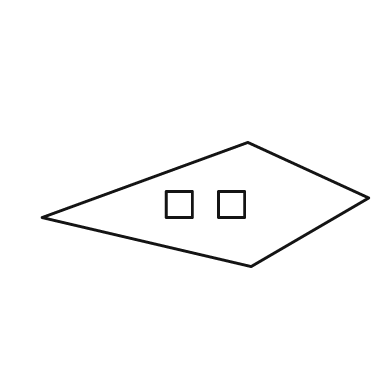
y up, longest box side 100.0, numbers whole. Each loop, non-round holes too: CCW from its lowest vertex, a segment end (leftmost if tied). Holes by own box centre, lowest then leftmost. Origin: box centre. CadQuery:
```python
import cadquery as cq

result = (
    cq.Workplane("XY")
    .moveTo(14.0, -19.0)
    .lineTo(50.0, 2.0)
    .lineTo(13.0, 19.0)
    .lineTo(-50.0, -4.0)
    .close()
    .moveTo(-12.0, -4.0)
    .lineTo(-4.0, -4.0)
    .lineTo(-4.0, 4.0)
    .lineTo(-12.0, 4.0)
    .close()
    .moveTo(4.0, -4.0)
    .lineTo(12.0, -4.0)
    .lineTo(12.0, 4.0)
    .lineTo(4.0, 4.0)
    .close()
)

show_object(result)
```